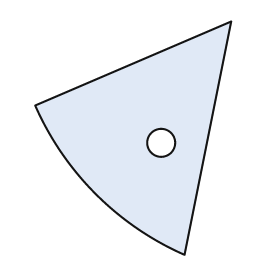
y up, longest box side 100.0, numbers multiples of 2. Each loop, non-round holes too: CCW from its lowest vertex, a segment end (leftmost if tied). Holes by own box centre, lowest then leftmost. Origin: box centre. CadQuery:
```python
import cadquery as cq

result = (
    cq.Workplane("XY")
    .moveTo(22.0, -50.0)
    .lineTo(42.0, 50.0)
    .lineTo(-42.0, 14.0)
    .threePointArc((-16.0, -24.0), (22.0, -50.0))
    .close()
    .moveTo(12.0, -2.0)
    .circle(6.0)
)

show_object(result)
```